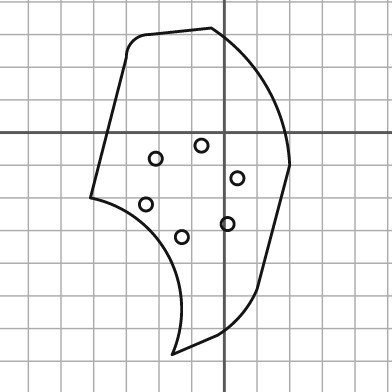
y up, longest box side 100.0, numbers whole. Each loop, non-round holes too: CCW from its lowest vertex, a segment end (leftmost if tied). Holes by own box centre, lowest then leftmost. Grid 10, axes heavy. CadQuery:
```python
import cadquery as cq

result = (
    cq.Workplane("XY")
    .moveTo(-16.0, -68.0)
    .lineTo(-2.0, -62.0)
    .threePointArc((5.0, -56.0), (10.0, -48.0))
    .lineTo(20.0, -10.0)
    .threePointArc((13.0, 14.0), (-4.0, 32.0))
    .lineTo(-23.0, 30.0)
    .threePointArc((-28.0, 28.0), (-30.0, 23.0))
    .lineTo(-41.0, -20.0)
    .threePointArc((-17.0, -38.0), (-16.0, -68.0))
    .close()
    .moveTo(-13.0, -32.0)
    .circle(2.0)
    .moveTo(1.0, -28.0)
    .circle(2.0)
    .moveTo(-24.0, -22.0)
    .circle(2.0)
    .moveTo(4.0, -14.0)
    .circle(2.0)
    .moveTo(-21.0, -8.0)
    .circle(2.0)
    .moveTo(-7.0, -4.0)
    .circle(2.0)
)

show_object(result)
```